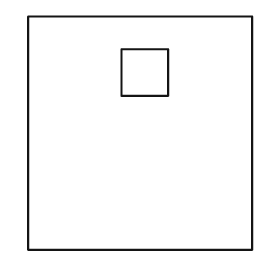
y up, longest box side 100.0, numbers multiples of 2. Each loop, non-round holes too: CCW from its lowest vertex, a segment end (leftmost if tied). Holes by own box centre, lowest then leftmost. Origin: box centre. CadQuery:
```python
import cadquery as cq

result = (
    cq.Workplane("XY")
    .moveTo(-48.0, -50.0)
    .lineTo(48.0, -50.0)
    .lineTo(48.0, 50.0)
    .lineTo(-48.0, 50.0)
    .close()
    .moveTo(-8.0, 16.0)
    .lineTo(12.0, 16.0)
    .lineTo(12.0, 36.0)
    .lineTo(-8.0, 36.0)
    .close()
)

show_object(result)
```